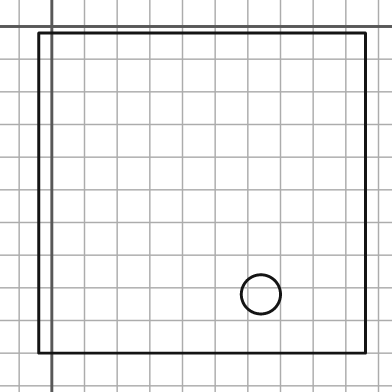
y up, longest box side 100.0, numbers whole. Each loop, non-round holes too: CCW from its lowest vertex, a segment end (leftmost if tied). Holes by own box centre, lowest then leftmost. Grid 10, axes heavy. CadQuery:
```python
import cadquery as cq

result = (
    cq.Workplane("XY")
    .moveTo(-4.0, -100.0)
    .lineTo(96.0, -100.0)
    .lineTo(96.0, -2.0)
    .lineTo(-4.0, -2.0)
    .close()
    .moveTo(64.0, -82.0)
    .circle(6.0)
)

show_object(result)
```